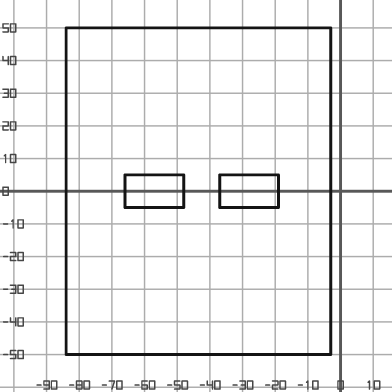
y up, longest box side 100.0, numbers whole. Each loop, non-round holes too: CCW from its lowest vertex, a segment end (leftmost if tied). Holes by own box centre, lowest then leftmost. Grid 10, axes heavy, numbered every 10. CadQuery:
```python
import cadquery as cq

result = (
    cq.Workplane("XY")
    .moveTo(-84.0, -50.0)
    .lineTo(-3.0, -50.0)
    .lineTo(-3.0, 50.0)
    .lineTo(-84.0, 50.0)
    .close()
    .moveTo(-66.0, -5.0)
    .lineTo(-48.0, -5.0)
    .lineTo(-48.0, 5.0)
    .lineTo(-66.0, 5.0)
    .close()
    .moveTo(-37.0, -5.0)
    .lineTo(-19.0, -5.0)
    .lineTo(-19.0, 5.0)
    .lineTo(-37.0, 5.0)
    .close()
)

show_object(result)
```